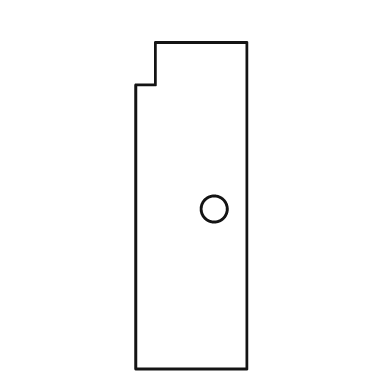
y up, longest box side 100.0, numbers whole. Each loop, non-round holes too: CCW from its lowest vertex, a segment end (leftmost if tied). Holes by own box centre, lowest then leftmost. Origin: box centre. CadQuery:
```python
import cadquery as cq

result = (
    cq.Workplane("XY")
    .moveTo(-17.0, -50.0)
    .lineTo(17.0, -50.0)
    .lineTo(17.0, 50.0)
    .lineTo(-11.0, 50.0)
    .lineTo(-11.0, 37.0)
    .lineTo(-17.0, 37.0)
    .close()
    .moveTo(7.0, -1.0)
    .circle(4.0)
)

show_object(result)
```